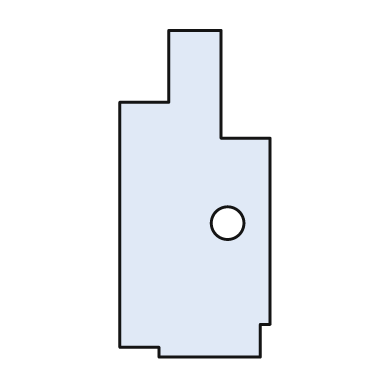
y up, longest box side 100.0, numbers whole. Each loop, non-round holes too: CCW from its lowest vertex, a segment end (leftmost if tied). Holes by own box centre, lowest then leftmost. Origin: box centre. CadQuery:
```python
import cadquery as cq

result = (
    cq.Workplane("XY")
    .moveTo(-11.0, -50.0)
    .lineTo(20.0, -50.0)
    .lineTo(20.0, -40.0)
    .lineTo(23.0, -40.0)
    .lineTo(23.0, 17.0)
    .lineTo(8.0, 17.0)
    .lineTo(8.0, 50.0)
    .lineTo(-8.0, 50.0)
    .lineTo(-8.0, 28.0)
    .lineTo(-23.0, 28.0)
    .lineTo(-23.0, -47.0)
    .lineTo(-11.0, -47.0)
    .close()
    .moveTo(10.0, -9.0)
    .circle(5.0)
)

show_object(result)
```